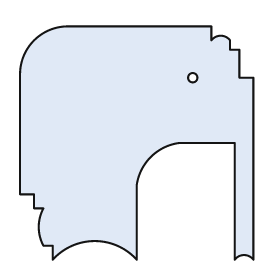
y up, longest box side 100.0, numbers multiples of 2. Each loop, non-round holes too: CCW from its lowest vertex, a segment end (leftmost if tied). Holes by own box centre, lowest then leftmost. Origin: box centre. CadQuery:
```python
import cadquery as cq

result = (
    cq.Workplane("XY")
    .moveTo(-36.0, -50.0)
    .threePointArc((-18.0, -42.0), (0.0, -50.0))
    .lineTo(0.0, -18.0)
    .threePointArc((6.0, -6.0), (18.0, 0.0))
    .lineTo(42.0, 0.0)
    .lineTo(42.0, -50.0)
    .threePointArc((46.0, -48.0), (50.0, -50.0))
    .lineTo(50.0, 28.0)
    .lineTo(44.0, 28.0)
    .lineTo(44.0, 40.0)
    .lineTo(40.0, 40.0)
    .lineTo(40.0, 44.0)
    .threePointArc((36.0, 46.0), (32.0, 44.0))
    .lineTo(32.0, 50.0)
    .lineTo(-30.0, 50.0)
    .threePointArc((-44.0, 44.0), (-50.0, 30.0))
    .lineTo(-50.0, -22.0)
    .lineTo(-44.0, -22.0)
    .lineTo(-44.0, -28.0)
    .lineTo(-40.0, -28.0)
    .threePointArc((-42.0, -36.0), (-40.0, -44.0))
    .lineTo(-36.0, -44.0)
    .close()
    .moveTo(24.0, 28.0)
    .circle(2.0)
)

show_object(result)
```